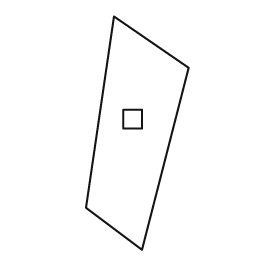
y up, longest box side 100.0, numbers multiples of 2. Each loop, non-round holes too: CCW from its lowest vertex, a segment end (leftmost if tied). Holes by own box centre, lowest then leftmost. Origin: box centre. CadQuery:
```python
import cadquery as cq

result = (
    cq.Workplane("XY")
    .moveTo(2.0, -50.0)
    .lineTo(22.0, 28.0)
    .lineTo(-10.0, 50.0)
    .lineTo(-22.0, -32.0)
    .close()
    .moveTo(-6.0, 2.0)
    .lineTo(2.0, 2.0)
    .lineTo(2.0, 10.0)
    .lineTo(-6.0, 10.0)
    .close()
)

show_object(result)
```